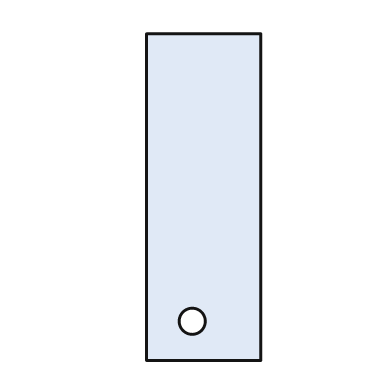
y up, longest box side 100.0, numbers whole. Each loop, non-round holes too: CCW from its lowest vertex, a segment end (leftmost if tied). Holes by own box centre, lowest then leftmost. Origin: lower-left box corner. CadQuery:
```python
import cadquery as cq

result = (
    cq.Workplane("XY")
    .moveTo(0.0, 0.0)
    .lineTo(35.0, 0.0)
    .lineTo(35.0, 100.0)
    .lineTo(0.0, 100.0)
    .close()
    .moveTo(14.0, 12.0)
    .circle(4.0)
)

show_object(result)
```